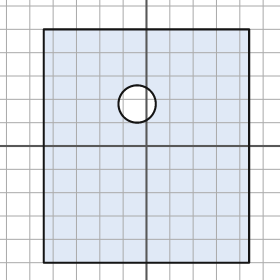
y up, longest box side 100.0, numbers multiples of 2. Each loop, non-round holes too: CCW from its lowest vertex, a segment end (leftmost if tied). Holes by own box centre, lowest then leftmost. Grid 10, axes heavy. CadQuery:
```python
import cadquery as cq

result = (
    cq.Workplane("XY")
    .moveTo(-44.0, -50.0)
    .lineTo(44.0, -50.0)
    .lineTo(44.0, 50.0)
    .lineTo(-44.0, 50.0)
    .close()
    .moveTo(-4.0, 18.0)
    .circle(8.0)
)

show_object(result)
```